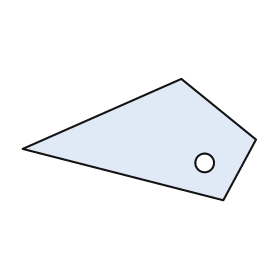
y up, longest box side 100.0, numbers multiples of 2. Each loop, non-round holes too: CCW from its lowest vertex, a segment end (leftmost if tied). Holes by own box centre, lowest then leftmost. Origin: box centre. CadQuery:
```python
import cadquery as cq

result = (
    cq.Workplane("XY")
    .moveTo(36.0, -26.0)
    .lineTo(50.0, 0.0)
    .lineTo(18.0, 26.0)
    .lineTo(-50.0, -4.0)
    .close()
    .moveTo(28.0, -10.0)
    .circle(4.0)
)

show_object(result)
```